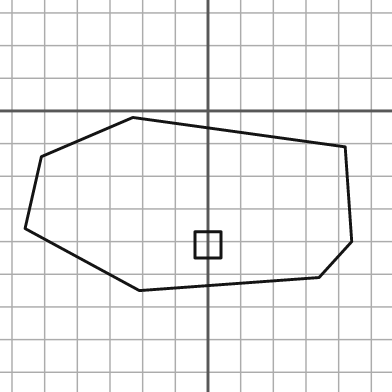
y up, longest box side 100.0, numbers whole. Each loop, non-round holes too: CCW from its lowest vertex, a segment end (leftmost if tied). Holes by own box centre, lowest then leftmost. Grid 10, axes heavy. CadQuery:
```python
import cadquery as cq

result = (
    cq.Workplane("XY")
    .moveTo(-21.0, -55.0)
    .lineTo(34.0, -51.0)
    .lineTo(44.0, -40.0)
    .lineTo(42.0, -11.0)
    .lineTo(-23.0, -2.0)
    .lineTo(-51.0, -14.0)
    .lineTo(-56.0, -36.0)
    .close()
    .moveTo(-4.0, -45.0)
    .lineTo(4.0, -45.0)
    .lineTo(4.0, -37.0)
    .lineTo(-4.0, -37.0)
    .close()
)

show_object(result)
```